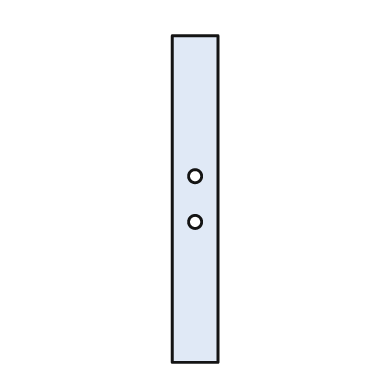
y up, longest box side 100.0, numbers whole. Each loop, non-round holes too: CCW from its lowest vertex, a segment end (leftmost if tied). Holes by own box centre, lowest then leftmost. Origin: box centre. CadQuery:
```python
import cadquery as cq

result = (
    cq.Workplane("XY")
    .moveTo(-7.0, -50.0)
    .lineTo(7.0, -50.0)
    .lineTo(7.0, 50.0)
    .lineTo(-7.0, 50.0)
    .close()
    .moveTo(0.0, -7.0)
    .circle(2.0)
    .moveTo(0.0, 7.0)
    .circle(2.0)
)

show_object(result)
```